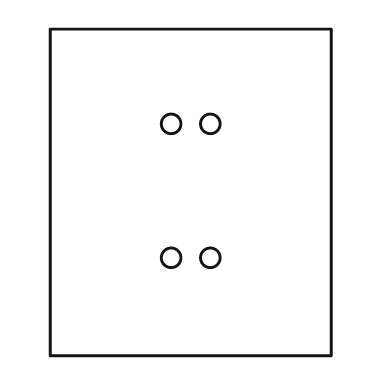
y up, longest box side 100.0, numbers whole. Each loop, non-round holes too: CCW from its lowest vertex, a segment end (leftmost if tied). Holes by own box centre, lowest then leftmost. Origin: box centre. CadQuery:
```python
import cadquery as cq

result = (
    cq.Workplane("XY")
    .moveTo(-43.0, -50.0)
    .lineTo(43.0, -50.0)
    .lineTo(43.0, 50.0)
    .lineTo(-43.0, 50.0)
    .close()
    .moveTo(-6.0, -20.0)
    .circle(3.0)
    .moveTo(6.0, -20.0)
    .circle(3.0)
    .moveTo(-6.0, 21.0)
    .circle(3.0)
    .moveTo(6.0, 21.0)
    .circle(3.0)
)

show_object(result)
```